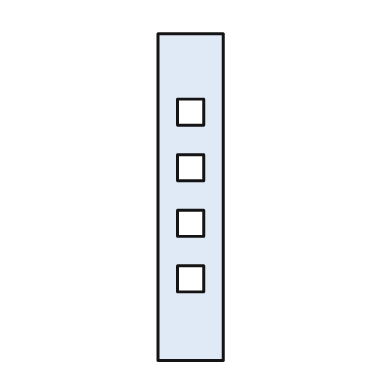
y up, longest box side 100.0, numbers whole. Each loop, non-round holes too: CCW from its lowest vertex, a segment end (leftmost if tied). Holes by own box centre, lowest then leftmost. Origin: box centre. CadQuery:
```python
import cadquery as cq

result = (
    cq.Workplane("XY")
    .moveTo(-10.0, -50.0)
    .lineTo(10.0, -50.0)
    .lineTo(10.0, 50.0)
    .lineTo(-10.0, 50.0)
    .close()
    .moveTo(-4.0, -29.0)
    .lineTo(4.0, -29.0)
    .lineTo(4.0, -21.0)
    .lineTo(-4.0, -21.0)
    .close()
    .moveTo(-4.0, -12.0)
    .lineTo(4.0, -12.0)
    .lineTo(4.0, -4.0)
    .lineTo(-4.0, -4.0)
    .close()
    .moveTo(-4.0, 5.0)
    .lineTo(4.0, 5.0)
    .lineTo(4.0, 13.0)
    .lineTo(-4.0, 13.0)
    .close()
    .moveTo(-4.0, 22.0)
    .lineTo(4.0, 22.0)
    .lineTo(4.0, 30.0)
    .lineTo(-4.0, 30.0)
    .close()
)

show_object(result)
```